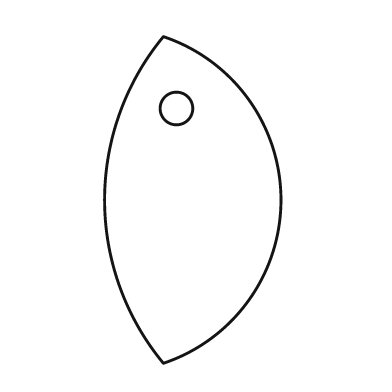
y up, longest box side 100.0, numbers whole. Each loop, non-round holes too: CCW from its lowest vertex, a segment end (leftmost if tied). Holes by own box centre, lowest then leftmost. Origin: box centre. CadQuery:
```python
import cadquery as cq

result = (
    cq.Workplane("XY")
    .moveTo(-9.0, -50.0)
    .threePointArc((27.0, 0.0), (-9.0, 50.0))
    .threePointArc((-27.0, 0.0), (-9.0, -50.0))
    .close()
    .moveTo(-5.0, 28.0)
    .circle(5.0)
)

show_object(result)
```